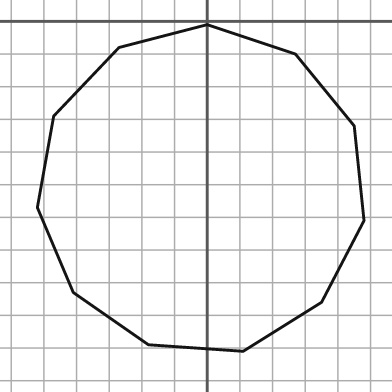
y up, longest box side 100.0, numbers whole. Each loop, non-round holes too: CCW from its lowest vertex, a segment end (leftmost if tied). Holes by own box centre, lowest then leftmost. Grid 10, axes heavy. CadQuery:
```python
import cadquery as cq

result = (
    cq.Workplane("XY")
    .moveTo(11.0, -101.0)
    .lineTo(35.0, -86.0)
    .lineTo(48.0, -61.0)
    .lineTo(45.0, -32.0)
    .lineTo(27.0, -10.0)
    .lineTo(0.0, -1.0)
    .lineTo(-27.0, -8.0)
    .lineTo(-47.0, -29.0)
    .lineTo(-52.0, -57.0)
    .lineTo(-41.0, -83.0)
    .lineTo(-18.0, -99.0)
    .close()
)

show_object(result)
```